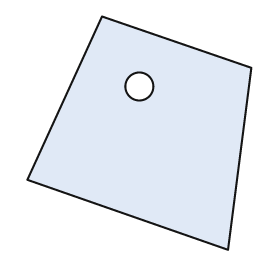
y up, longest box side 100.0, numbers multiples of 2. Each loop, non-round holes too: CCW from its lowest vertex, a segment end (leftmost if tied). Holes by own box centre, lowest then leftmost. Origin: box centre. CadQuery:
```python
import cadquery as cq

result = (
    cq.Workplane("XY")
    .moveTo(38.0, -50.0)
    .lineTo(48.0, 28.0)
    .lineTo(-16.0, 50.0)
    .lineTo(-48.0, -20.0)
    .close()
    .moveTo(0.0, 20.0)
    .circle(6.0)
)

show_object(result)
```